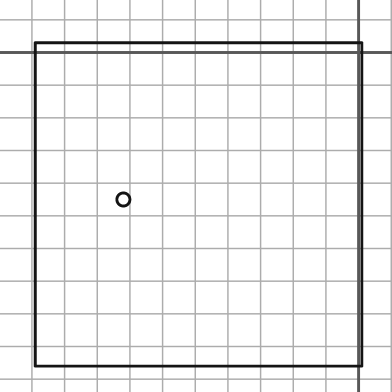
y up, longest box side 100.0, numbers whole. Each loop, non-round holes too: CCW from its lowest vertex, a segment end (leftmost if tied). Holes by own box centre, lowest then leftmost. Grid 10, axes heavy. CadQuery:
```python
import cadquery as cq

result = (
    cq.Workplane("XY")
    .moveTo(-99.0, -96.0)
    .lineTo(1.0, -96.0)
    .lineTo(1.0, 3.0)
    .lineTo(-99.0, 3.0)
    .close()
    .moveTo(-72.0, -45.0)
    .circle(2.0)
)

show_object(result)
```